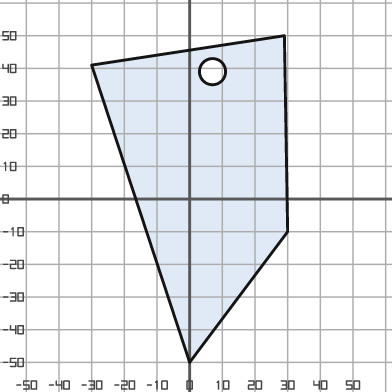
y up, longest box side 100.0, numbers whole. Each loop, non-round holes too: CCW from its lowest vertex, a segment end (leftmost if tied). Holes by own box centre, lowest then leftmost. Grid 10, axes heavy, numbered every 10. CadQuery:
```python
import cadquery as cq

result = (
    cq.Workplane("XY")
    .moveTo(0.0, -50.0)
    .lineTo(30.0, -10.0)
    .lineTo(29.0, 50.0)
    .lineTo(-30.0, 41.0)
    .close()
    .moveTo(7.0, 39.0)
    .circle(4.0)
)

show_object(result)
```